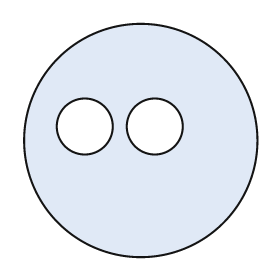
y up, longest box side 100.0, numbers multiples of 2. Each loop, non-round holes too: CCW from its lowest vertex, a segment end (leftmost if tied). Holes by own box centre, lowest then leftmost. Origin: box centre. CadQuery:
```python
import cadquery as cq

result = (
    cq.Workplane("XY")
    .moveTo(0.0, 0.0)
    .circle(50.0)
    .moveTo(-24.0, 6.0)
    .circle(12.0)
    .moveTo(6.0, 6.0)
    .circle(12.0)
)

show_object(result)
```